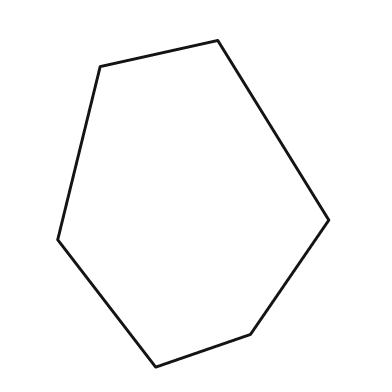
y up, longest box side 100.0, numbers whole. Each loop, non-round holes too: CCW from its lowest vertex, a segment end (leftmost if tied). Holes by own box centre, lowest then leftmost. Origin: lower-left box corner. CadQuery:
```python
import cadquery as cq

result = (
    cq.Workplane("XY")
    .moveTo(30.0, 0.0)
    .lineTo(59.0, 10.0)
    .lineTo(83.0, 45.0)
    .lineTo(49.0, 100.0)
    .lineTo(13.0, 92.0)
    .lineTo(0.0, 39.0)
    .close()
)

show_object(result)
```